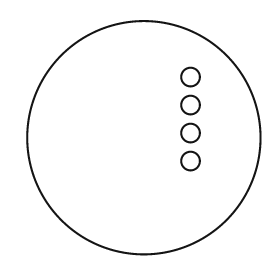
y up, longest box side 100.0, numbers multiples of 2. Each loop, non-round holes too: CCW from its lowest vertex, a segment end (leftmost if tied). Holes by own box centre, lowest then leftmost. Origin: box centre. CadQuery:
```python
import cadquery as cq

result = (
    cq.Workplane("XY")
    .moveTo(0.0, 0.0)
    .circle(50.0)
    .moveTo(20.0, -10.0)
    .circle(4.0)
    .moveTo(20.0, 2.0)
    .circle(4.0)
    .moveTo(20.0, 14.0)
    .circle(4.0)
    .moveTo(20.0, 26.0)
    .circle(4.0)
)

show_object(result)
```